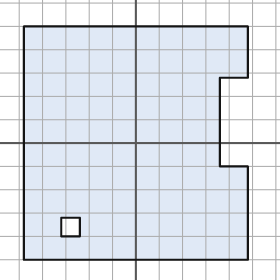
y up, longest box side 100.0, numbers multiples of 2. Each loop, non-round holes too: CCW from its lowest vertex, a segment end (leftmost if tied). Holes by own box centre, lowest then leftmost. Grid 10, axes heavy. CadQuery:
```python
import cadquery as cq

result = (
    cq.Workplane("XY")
    .moveTo(-48.0, -50.0)
    .lineTo(48.0, -50.0)
    .lineTo(48.0, -10.0)
    .lineTo(36.0, -10.0)
    .lineTo(36.0, 28.0)
    .lineTo(48.0, 28.0)
    .lineTo(48.0, 50.0)
    .lineTo(-48.0, 50.0)
    .close()
    .moveTo(-32.0, -40.0)
    .lineTo(-24.0, -40.0)
    .lineTo(-24.0, -32.0)
    .lineTo(-32.0, -32.0)
    .close()
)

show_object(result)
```